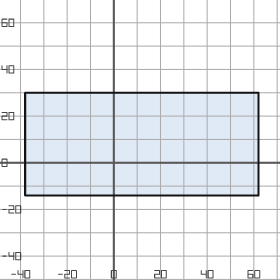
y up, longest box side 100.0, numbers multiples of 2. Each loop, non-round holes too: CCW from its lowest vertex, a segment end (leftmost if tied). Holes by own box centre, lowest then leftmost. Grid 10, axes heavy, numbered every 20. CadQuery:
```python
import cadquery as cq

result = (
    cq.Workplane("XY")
    .moveTo(-38.0, -14.0)
    .lineTo(62.0, -14.0)
    .lineTo(62.0, 30.0)
    .lineTo(-38.0, 30.0)
    .close()
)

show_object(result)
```